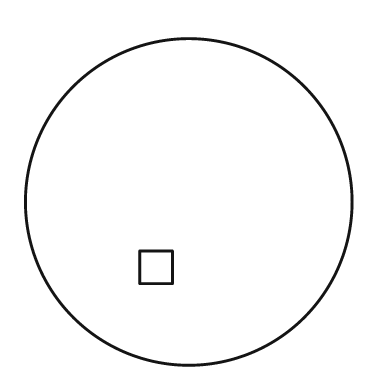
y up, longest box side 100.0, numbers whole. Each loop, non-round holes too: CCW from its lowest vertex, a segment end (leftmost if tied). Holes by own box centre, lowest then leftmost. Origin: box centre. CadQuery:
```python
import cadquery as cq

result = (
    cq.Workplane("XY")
    .moveTo(0.0, 0.0)
    .circle(50.0)
    .moveTo(-15.0, -25.0)
    .lineTo(-5.0, -25.0)
    .lineTo(-5.0, -15.0)
    .lineTo(-15.0, -15.0)
    .close()
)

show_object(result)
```